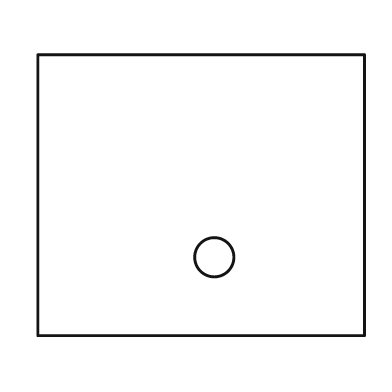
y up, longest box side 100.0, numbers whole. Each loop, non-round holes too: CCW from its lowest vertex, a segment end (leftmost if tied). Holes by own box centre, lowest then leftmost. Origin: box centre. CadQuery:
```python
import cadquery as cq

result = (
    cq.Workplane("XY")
    .moveTo(-50.0, -43.0)
    .lineTo(50.0, -43.0)
    .lineTo(50.0, 43.0)
    .lineTo(-50.0, 43.0)
    .close()
    .moveTo(4.0, -19.0)
    .circle(6.0)
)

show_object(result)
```